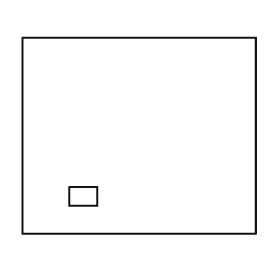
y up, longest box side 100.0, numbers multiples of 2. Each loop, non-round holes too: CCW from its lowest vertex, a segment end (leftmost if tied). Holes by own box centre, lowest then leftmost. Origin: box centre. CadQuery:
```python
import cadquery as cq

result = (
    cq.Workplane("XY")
    .moveTo(-50.0, -42.0)
    .lineTo(50.0, -42.0)
    .lineTo(50.0, 42.0)
    .lineTo(-50.0, 42.0)
    .close()
    .moveTo(-30.0, -30.0)
    .lineTo(-18.0, -30.0)
    .lineTo(-18.0, -22.0)
    .lineTo(-30.0, -22.0)
    .close()
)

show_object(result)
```